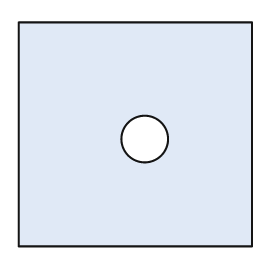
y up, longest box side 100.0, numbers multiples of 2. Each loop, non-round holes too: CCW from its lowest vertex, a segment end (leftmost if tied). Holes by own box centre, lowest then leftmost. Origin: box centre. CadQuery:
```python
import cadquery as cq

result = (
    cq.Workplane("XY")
    .moveTo(-50.0, -48.0)
    .lineTo(50.0, -48.0)
    .lineTo(50.0, 48.0)
    .lineTo(-50.0, 48.0)
    .close()
    .moveTo(4.0, -2.0)
    .circle(10.0)
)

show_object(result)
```